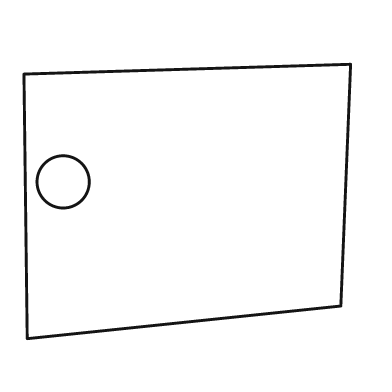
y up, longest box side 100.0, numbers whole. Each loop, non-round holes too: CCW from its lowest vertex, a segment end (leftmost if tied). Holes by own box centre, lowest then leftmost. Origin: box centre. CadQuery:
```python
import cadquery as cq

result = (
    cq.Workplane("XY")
    .moveTo(-49.0, -42.0)
    .lineTo(47.0, -32.0)
    .lineTo(50.0, 42.0)
    .lineTo(-50.0, 39.0)
    .close()
    .moveTo(-38.0, 6.0)
    .circle(8.0)
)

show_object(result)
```